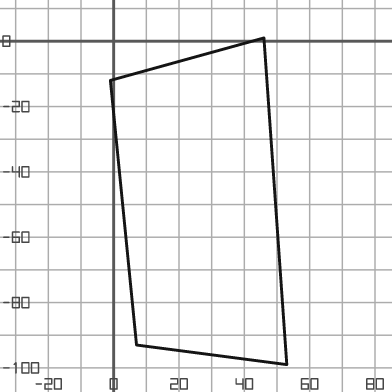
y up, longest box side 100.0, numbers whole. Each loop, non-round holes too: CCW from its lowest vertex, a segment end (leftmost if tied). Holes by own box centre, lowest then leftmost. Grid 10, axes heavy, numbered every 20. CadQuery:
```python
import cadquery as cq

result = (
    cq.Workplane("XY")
    .moveTo(53.0, -99.0)
    .lineTo(46.0, 1.0)
    .lineTo(-1.0, -12.0)
    .lineTo(7.0, -93.0)
    .close()
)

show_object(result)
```